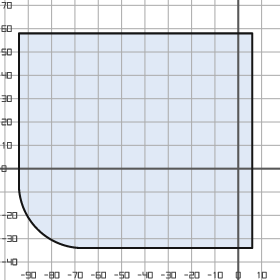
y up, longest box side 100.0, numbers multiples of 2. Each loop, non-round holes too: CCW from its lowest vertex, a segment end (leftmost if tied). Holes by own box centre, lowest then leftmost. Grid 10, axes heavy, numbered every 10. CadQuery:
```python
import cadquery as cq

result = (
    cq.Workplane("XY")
    .moveTo(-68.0, -34.0)
    .lineTo(6.0, -34.0)
    .lineTo(6.0, 58.0)
    .lineTo(-94.0, 58.0)
    .lineTo(-94.0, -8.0)
    .threePointArc((-86.0, -26.0), (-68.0, -34.0))
    .close()
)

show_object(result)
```